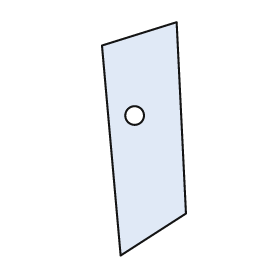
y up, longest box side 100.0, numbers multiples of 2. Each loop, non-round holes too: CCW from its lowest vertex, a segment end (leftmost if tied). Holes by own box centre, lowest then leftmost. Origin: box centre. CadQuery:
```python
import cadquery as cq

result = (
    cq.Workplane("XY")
    .moveTo(-10.0, -50.0)
    .lineTo(18.0, -32.0)
    .lineTo(14.0, 50.0)
    .lineTo(-18.0, 40.0)
    .close()
    .moveTo(-4.0, 10.0)
    .circle(4.0)
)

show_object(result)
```